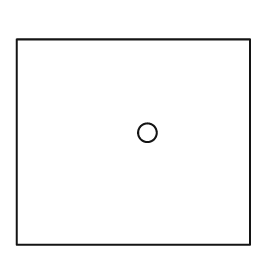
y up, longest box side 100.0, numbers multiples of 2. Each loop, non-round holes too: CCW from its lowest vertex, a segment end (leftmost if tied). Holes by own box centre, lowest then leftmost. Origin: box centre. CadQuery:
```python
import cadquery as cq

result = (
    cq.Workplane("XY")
    .moveTo(-50.0, -44.0)
    .lineTo(50.0, -44.0)
    .lineTo(50.0, 44.0)
    .lineTo(-50.0, 44.0)
    .close()
    .moveTo(6.0, 4.0)
    .circle(4.0)
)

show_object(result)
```